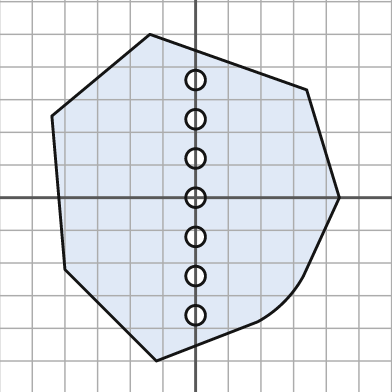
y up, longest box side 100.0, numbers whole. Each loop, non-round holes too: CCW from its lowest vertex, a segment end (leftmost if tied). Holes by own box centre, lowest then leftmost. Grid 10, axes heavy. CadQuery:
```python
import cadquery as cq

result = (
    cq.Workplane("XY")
    .moveTo(-12.0, -50.0)
    .lineTo(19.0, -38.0)
    .threePointArc((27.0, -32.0), (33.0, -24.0))
    .lineTo(44.0, 0.0)
    .lineTo(34.0, 33.0)
    .lineTo(-14.0, 50.0)
    .lineTo(-44.0, 25.0)
    .lineTo(-40.0, -22.0)
    .close()
    .moveTo(0.0, -36.0)
    .circle(3.0)
    .moveTo(0.0, -24.0)
    .circle(3.0)
    .moveTo(0.0, -12.0)
    .circle(3.0)
    .moveTo(0.0, 0.0)
    .circle(3.0)
    .moveTo(0.0, 12.0)
    .circle(3.0)
    .moveTo(0.0, 24.0)
    .circle(3.0)
    .moveTo(0.0, 36.0)
    .circle(3.0)
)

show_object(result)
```